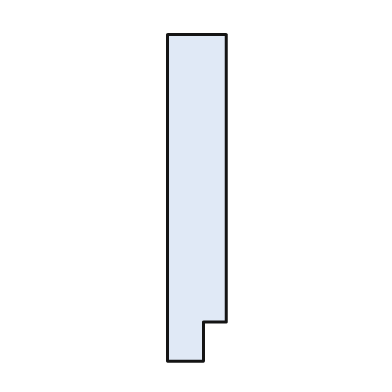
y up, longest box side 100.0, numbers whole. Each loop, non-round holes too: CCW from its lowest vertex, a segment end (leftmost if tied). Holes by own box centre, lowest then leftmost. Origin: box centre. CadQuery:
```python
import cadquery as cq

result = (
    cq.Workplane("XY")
    .moveTo(-9.0, -50.0)
    .lineTo(2.0, -50.0)
    .lineTo(2.0, -38.0)
    .lineTo(9.0, -38.0)
    .lineTo(9.0, 50.0)
    .lineTo(-9.0, 50.0)
    .close()
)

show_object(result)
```